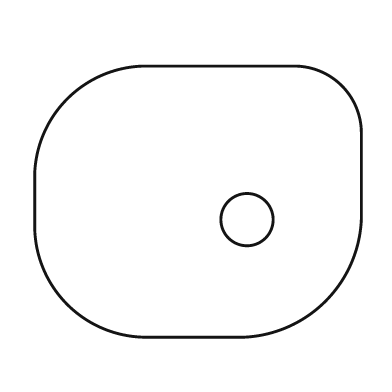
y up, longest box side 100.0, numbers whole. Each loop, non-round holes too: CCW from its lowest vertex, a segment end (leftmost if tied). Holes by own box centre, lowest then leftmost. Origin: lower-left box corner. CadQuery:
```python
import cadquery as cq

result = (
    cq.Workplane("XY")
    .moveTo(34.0, 0.0)
    .lineTo(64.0, 0.0)
    .threePointArc((89.0, 11.0), (100.0, 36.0))
    .lineTo(100.0, 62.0)
    .threePointArc((94.0, 77.0), (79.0, 83.0))
    .lineTo(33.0, 83.0)
    .threePointArc((10.0, 73.0), (0.0, 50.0))
    .lineTo(0.0, 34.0)
    .threePointArc((10.0, 10.0), (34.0, 0.0))
    .close()
    .moveTo(65.0, 36.0)
    .circle(8.0)
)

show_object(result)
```